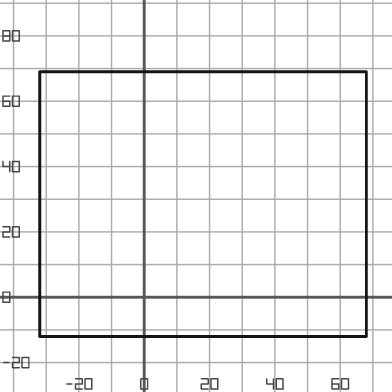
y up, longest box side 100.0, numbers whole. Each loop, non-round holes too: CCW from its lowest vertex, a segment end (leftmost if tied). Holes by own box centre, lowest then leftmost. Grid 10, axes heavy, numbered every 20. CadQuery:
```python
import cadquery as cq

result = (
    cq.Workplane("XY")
    .moveTo(-32.0, -12.0)
    .lineTo(68.0, -12.0)
    .lineTo(68.0, 69.0)
    .lineTo(-32.0, 69.0)
    .close()
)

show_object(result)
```